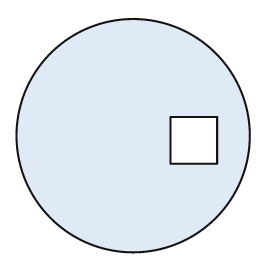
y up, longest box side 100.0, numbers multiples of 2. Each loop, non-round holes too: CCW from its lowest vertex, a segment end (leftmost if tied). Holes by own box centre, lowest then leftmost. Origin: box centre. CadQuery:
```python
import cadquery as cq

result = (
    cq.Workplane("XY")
    .moveTo(0.0, 0.0)
    .circle(50.0)
    .moveTo(16.0, -12.0)
    .lineTo(36.0, -12.0)
    .lineTo(36.0, 8.0)
    .lineTo(16.0, 8.0)
    .close()
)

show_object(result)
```